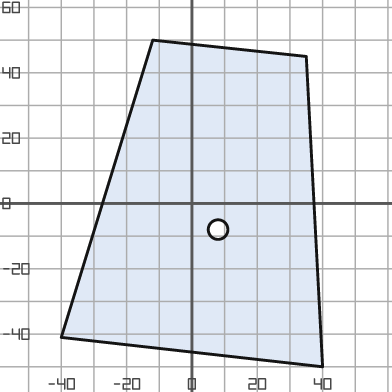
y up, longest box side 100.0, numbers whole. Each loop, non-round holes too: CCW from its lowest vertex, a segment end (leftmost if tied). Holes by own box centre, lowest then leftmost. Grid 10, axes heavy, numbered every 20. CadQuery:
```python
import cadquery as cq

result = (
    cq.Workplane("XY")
    .moveTo(40.0, -50.0)
    .lineTo(35.0, 45.0)
    .lineTo(-12.0, 50.0)
    .lineTo(-40.0, -41.0)
    .close()
    .moveTo(8.0, -8.0)
    .circle(3.0)
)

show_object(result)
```